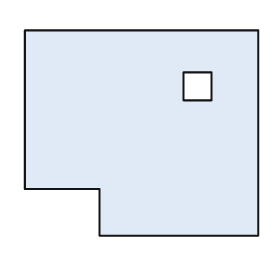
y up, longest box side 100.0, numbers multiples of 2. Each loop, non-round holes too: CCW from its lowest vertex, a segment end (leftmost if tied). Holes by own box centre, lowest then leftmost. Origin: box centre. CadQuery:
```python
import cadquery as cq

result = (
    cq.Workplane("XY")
    .moveTo(-18.0, -44.0)
    .lineTo(50.0, -44.0)
    .lineTo(50.0, 44.0)
    .lineTo(-50.0, 44.0)
    .lineTo(-50.0, -24.0)
    .lineTo(-18.0, -24.0)
    .close()
    .moveTo(18.0, 14.0)
    .lineTo(30.0, 14.0)
    .lineTo(30.0, 26.0)
    .lineTo(18.0, 26.0)
    .close()
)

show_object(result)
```